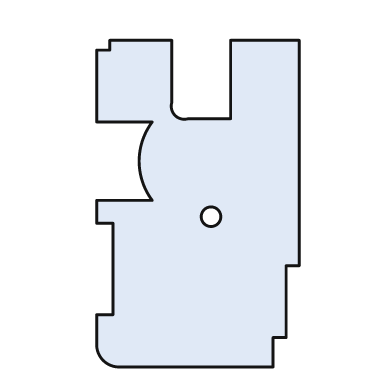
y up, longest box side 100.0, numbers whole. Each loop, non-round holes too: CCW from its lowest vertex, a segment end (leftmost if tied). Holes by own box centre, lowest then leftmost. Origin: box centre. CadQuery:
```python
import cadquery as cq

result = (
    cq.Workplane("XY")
    .moveTo(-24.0, -50.0)
    .lineTo(23.0, -50.0)
    .lineTo(23.0, -41.0)
    .lineTo(27.0, -41.0)
    .lineTo(27.0, -19.0)
    .lineTo(31.0, -19.0)
    .lineTo(31.0, 50.0)
    .lineTo(10.0, 50.0)
    .lineTo(10.0, 26.0)
    .lineTo(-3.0, 26.0)
    .threePointArc((-7.0, 27.0), (-8.0, 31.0))
    .lineTo(-8.0, 50.0)
    .lineTo(-27.0, 50.0)
    .lineTo(-27.0, 47.0)
    .lineTo(-31.0, 47.0)
    .lineTo(-31.0, 25.0)
    .lineTo(-14.0, 25.0)
    .threePointArc((-18.0, 13.0), (-14.0, 1.0))
    .lineTo(-31.0, 1.0)
    .lineTo(-31.0, -6.0)
    .lineTo(-26.0, -6.0)
    .lineTo(-26.0, -34.0)
    .lineTo(-31.0, -34.0)
    .lineTo(-31.0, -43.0)
    .threePointArc((-29.0, -48.0), (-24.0, -50.0))
    .close()
    .moveTo(4.0, -4.0)
    .circle(3.0)
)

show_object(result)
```